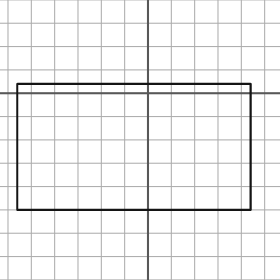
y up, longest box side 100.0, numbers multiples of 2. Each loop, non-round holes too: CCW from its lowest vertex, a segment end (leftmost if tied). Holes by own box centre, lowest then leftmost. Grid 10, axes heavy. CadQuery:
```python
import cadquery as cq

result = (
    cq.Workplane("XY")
    .moveTo(-56.0, -50.0)
    .lineTo(44.0, -50.0)
    .lineTo(44.0, 4.0)
    .lineTo(-56.0, 4.0)
    .close()
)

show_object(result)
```